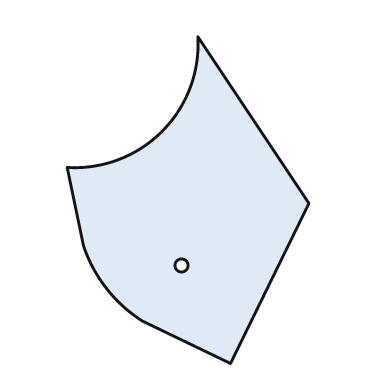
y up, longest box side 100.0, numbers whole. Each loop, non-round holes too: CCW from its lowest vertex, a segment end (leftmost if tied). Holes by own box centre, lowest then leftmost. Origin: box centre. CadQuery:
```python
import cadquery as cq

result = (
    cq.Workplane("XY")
    .moveTo(13.0, -50.0)
    .lineTo(37.0, -1.0)
    .lineTo(3.0, 50.0)
    .threePointArc((-8.0, 21.0), (-37.0, 10.0))
    .lineTo(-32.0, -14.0)
    .threePointArc((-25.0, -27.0), (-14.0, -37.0))
    .close()
    .moveTo(-2.0, -20.0)
    .circle(2.0)
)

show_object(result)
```